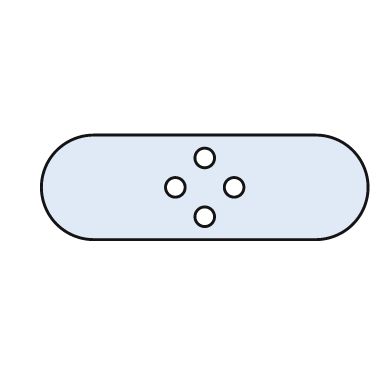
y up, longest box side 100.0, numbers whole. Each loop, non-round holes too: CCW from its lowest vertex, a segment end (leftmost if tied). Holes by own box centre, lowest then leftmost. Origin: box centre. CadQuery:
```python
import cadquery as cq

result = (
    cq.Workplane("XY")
    .moveTo(-34.0, -16.0)
    .lineTo(34.0, -16.0)
    .threePointArc((50.0, 0.0), (34.0, 16.0))
    .lineTo(-34.0, 16.0)
    .threePointArc((-50.0, 0.0), (-34.0, -16.0))
    .close()
    .moveTo(0.0, -9.0)
    .circle(3.0)
    .moveTo(-9.0, 0.0)
    .circle(3.0)
    .moveTo(9.0, 0.0)
    .circle(3.0)
    .moveTo(0.0, 9.0)
    .circle(3.0)
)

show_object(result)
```